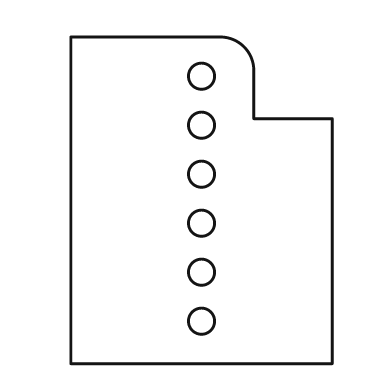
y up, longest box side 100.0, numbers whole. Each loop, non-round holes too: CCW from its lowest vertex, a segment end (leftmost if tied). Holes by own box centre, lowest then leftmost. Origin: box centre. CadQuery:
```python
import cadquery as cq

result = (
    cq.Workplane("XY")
    .moveTo(-40.0, -50.0)
    .lineTo(40.0, -50.0)
    .lineTo(40.0, 25.0)
    .lineTo(16.0, 25.0)
    .lineTo(16.0, 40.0)
    .threePointArc((13.0, 47.0), (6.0, 50.0))
    .lineTo(-40.0, 50.0)
    .close()
    .moveTo(0.0, -37.0)
    .circle(4.0)
    .moveTo(0.0, -22.0)
    .circle(4.0)
    .moveTo(0.0, -7.0)
    .circle(4.0)
    .moveTo(0.0, 8.0)
    .circle(4.0)
    .moveTo(0.0, 23.0)
    .circle(4.0)
    .moveTo(0.0, 38.0)
    .circle(4.0)
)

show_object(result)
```